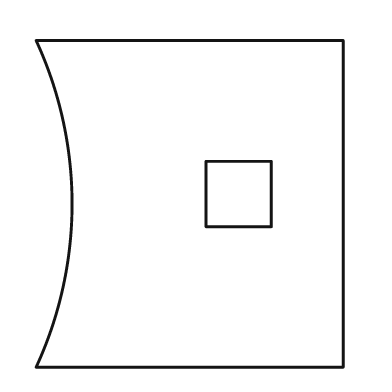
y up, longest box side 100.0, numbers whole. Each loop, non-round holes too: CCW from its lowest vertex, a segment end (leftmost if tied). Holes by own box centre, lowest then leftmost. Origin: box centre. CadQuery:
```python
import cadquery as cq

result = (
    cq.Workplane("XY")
    .moveTo(-47.0, -50.0)
    .lineTo(47.0, -50.0)
    .lineTo(47.0, 50.0)
    .lineTo(-47.0, 50.0)
    .threePointArc((-36.0, 0.0), (-47.0, -50.0))
    .close()
    .moveTo(5.0, -7.0)
    .lineTo(25.0, -7.0)
    .lineTo(25.0, 13.0)
    .lineTo(5.0, 13.0)
    .close()
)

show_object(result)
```